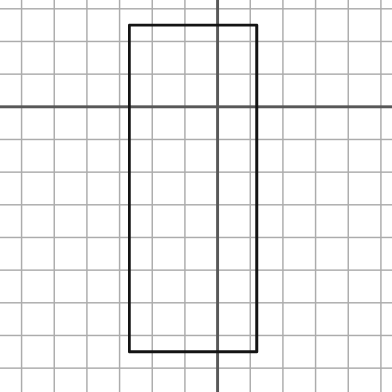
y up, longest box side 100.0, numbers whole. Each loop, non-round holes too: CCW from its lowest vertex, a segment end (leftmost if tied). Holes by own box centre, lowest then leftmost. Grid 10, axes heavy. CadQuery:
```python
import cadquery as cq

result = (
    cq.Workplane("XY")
    .moveTo(-27.0, -75.0)
    .lineTo(12.0, -75.0)
    .lineTo(12.0, 25.0)
    .lineTo(-27.0, 25.0)
    .close()
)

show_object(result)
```